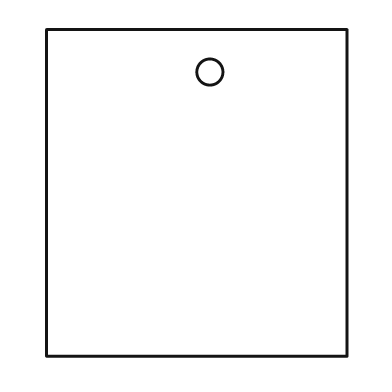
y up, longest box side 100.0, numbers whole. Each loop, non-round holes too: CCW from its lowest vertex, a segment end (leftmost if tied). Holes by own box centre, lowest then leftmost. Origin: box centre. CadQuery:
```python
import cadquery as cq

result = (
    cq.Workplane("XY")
    .moveTo(-46.0, -50.0)
    .lineTo(46.0, -50.0)
    .lineTo(46.0, 50.0)
    .lineTo(-46.0, 50.0)
    .close()
    .moveTo(4.0, 37.0)
    .circle(4.0)
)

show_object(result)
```